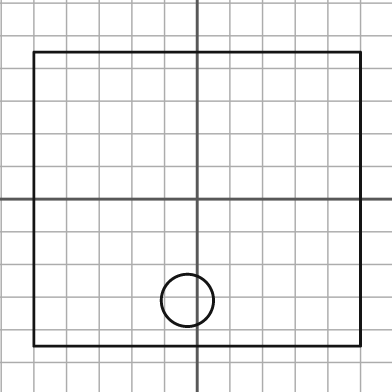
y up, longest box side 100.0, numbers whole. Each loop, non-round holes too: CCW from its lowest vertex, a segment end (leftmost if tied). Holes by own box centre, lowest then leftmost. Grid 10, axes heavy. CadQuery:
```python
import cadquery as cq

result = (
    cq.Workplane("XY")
    .moveTo(-50.0, -45.0)
    .lineTo(50.0, -45.0)
    .lineTo(50.0, 45.0)
    .lineTo(-50.0, 45.0)
    .close()
    .moveTo(-3.0, -31.0)
    .circle(8.0)
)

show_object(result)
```